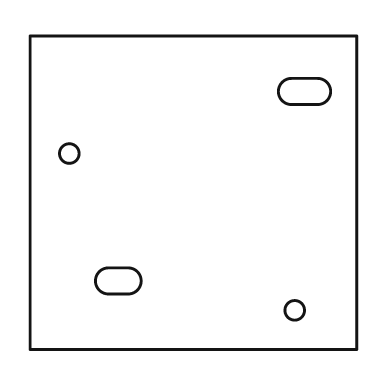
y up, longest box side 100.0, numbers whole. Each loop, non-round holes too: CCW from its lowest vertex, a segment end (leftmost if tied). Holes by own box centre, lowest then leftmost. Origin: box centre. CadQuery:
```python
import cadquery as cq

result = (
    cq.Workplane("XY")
    .moveTo(-50.0, -48.0)
    .lineTo(50.0, -48.0)
    .lineTo(50.0, 48.0)
    .lineTo(-50.0, 48.0)
    .close()
    .moveTo(31.0, -36.0)
    .circle(3.0)
    .moveTo(-26.0, -31.0)
    .lineTo(-20.0, -31.0)
    .threePointArc((-16.0, -27.0), (-20.0, -23.0))
    .lineTo(-26.0, -23.0)
    .threePointArc((-30.0, -27.0), (-26.0, -31.0))
    .close()
    .moveTo(-38.0, 12.0)
    .circle(3.0)
    .moveTo(30.0, 27.0)
    .lineTo(38.0, 27.0)
    .threePointArc((42.0, 31.0), (38.0, 35.0))
    .lineTo(30.0, 35.0)
    .threePointArc((26.0, 31.0), (30.0, 27.0))
    .close()
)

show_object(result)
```